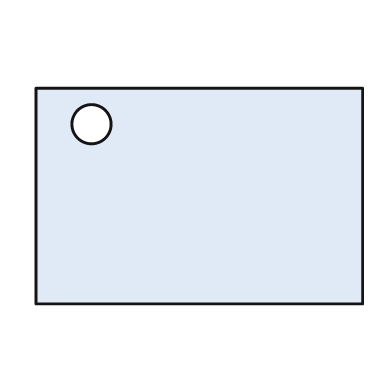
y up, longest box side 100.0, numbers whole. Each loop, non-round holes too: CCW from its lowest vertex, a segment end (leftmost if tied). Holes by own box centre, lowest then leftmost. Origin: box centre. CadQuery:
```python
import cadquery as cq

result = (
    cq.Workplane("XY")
    .moveTo(-50.0, -33.0)
    .lineTo(50.0, -33.0)
    .lineTo(50.0, 33.0)
    .lineTo(-50.0, 33.0)
    .close()
    .moveTo(-33.0, 22.0)
    .circle(6.0)
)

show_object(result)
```